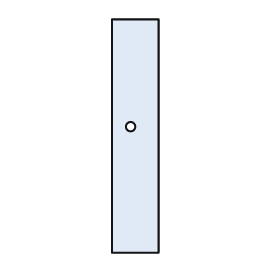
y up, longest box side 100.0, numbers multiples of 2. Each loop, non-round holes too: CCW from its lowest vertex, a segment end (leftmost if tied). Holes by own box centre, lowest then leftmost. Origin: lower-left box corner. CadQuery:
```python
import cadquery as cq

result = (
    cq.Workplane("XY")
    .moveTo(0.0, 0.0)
    .lineTo(20.0, 0.0)
    .lineTo(20.0, 100.0)
    .lineTo(0.0, 100.0)
    .close()
    .moveTo(8.0, 54.0)
    .circle(2.0)
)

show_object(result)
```